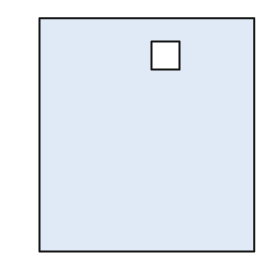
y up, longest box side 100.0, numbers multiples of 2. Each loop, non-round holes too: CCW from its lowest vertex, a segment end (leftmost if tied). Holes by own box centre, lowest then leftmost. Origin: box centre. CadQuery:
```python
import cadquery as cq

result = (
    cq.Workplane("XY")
    .moveTo(-46.0, -50.0)
    .lineTo(46.0, -50.0)
    .lineTo(46.0, 50.0)
    .lineTo(-46.0, 50.0)
    .close()
    .moveTo(2.0, 28.0)
    .lineTo(14.0, 28.0)
    .lineTo(14.0, 40.0)
    .lineTo(2.0, 40.0)
    .close()
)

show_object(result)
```